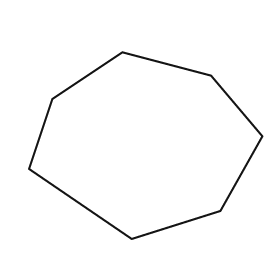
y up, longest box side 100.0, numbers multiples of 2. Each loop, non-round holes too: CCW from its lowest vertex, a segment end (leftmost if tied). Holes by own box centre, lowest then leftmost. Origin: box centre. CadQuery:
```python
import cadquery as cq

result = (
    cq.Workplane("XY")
    .moveTo(-6.0, -40.0)
    .lineTo(32.0, -28.0)
    .lineTo(50.0, 4.0)
    .lineTo(28.0, 30.0)
    .lineTo(-10.0, 40.0)
    .lineTo(-40.0, 20.0)
    .lineTo(-50.0, -10.0)
    .close()
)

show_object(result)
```